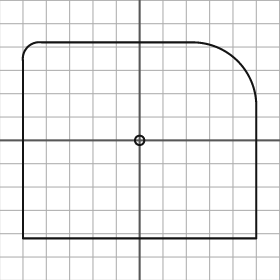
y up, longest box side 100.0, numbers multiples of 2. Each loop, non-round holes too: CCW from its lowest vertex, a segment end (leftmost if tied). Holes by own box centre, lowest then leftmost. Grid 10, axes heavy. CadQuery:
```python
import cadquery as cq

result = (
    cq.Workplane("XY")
    .moveTo(-50.0, -42.0)
    .lineTo(50.0, -42.0)
    .lineTo(50.0, 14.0)
    .threePointArc((42.0, 34.0), (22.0, 42.0))
    .lineTo(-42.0, 42.0)
    .threePointArc((-48.0, 40.0), (-50.0, 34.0))
    .close()
    .moveTo(0.0, 0.0)
    .circle(2.0)
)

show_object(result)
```